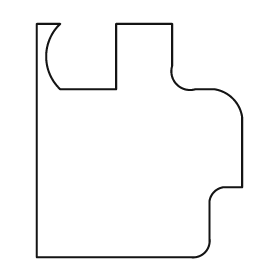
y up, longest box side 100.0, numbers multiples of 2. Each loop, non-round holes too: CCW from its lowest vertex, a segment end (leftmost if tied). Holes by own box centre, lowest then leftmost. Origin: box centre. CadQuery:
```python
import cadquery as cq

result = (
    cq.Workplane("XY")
    .moveTo(-44.0, -50.0)
    .lineTo(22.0, -50.0)
    .threePointArc((28.0, -48.0), (30.0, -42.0))
    .lineTo(30.0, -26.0)
    .threePointArc((32.0, -22.0), (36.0, -20.0))
    .lineTo(44.0, -20.0)
    .lineTo(44.0, 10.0)
    .threePointArc((40.0, 18.0), (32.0, 22.0))
    .lineTo(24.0, 22.0)
    .threePointArc((16.0, 24.0), (14.0, 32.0))
    .lineTo(14.0, 50.0)
    .lineTo(-10.0, 50.0)
    .lineTo(-10.0, 22.0)
    .lineTo(-34.0, 22.0)
    .threePointArc((-40.0, 36.0), (-34.0, 50.0))
    .lineTo(-44.0, 50.0)
    .close()
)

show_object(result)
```